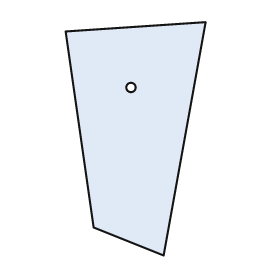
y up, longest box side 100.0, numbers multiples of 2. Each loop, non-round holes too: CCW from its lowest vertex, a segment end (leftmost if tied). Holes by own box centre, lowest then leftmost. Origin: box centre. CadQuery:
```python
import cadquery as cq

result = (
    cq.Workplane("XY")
    .moveTo(12.0, -50.0)
    .lineTo(30.0, 50.0)
    .lineTo(-30.0, 46.0)
    .lineTo(-18.0, -38.0)
    .close()
    .moveTo(-2.0, 22.0)
    .circle(2.0)
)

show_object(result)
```